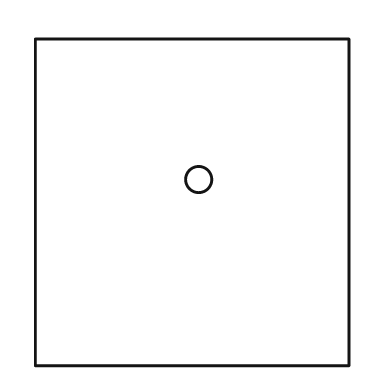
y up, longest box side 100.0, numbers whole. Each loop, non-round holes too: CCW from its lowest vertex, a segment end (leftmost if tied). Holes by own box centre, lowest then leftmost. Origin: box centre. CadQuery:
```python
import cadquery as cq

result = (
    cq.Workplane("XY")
    .moveTo(-48.0, -50.0)
    .lineTo(48.0, -50.0)
    .lineTo(48.0, 50.0)
    .lineTo(-48.0, 50.0)
    .close()
    .moveTo(2.0, 7.0)
    .circle(4.0)
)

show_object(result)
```